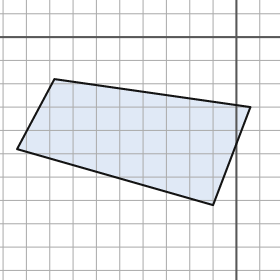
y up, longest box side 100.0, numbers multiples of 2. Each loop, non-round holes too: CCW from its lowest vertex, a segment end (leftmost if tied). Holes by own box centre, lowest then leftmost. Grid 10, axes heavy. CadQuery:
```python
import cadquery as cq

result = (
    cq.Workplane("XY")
    .moveTo(-10.0, -72.0)
    .lineTo(6.0, -30.0)
    .lineTo(-78.0, -18.0)
    .lineTo(-94.0, -48.0)
    .close()
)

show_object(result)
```